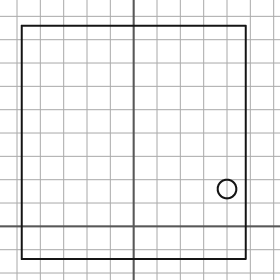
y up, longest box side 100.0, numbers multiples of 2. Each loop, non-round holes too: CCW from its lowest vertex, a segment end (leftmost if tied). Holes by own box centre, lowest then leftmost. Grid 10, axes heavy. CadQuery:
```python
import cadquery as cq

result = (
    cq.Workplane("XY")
    .moveTo(-48.0, -14.0)
    .lineTo(48.0, -14.0)
    .lineTo(48.0, 86.0)
    .lineTo(-48.0, 86.0)
    .close()
    .moveTo(40.0, 16.0)
    .circle(4.0)
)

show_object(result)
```